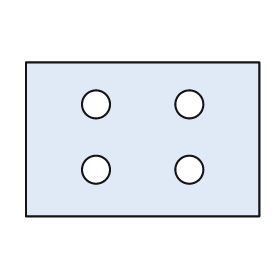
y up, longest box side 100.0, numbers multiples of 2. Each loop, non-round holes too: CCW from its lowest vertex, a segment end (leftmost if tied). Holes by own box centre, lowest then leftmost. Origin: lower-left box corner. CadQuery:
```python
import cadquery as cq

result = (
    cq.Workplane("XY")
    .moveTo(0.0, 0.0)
    .lineTo(100.0, 0.0)
    .lineTo(100.0, 66.0)
    .lineTo(0.0, 66.0)
    .close()
    .moveTo(30.0, 20.0)
    .circle(6.0)
    .moveTo(70.0, 20.0)
    .circle(6.0)
    .moveTo(30.0, 48.0)
    .circle(6.0)
    .moveTo(70.0, 48.0)
    .circle(6.0)
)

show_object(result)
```